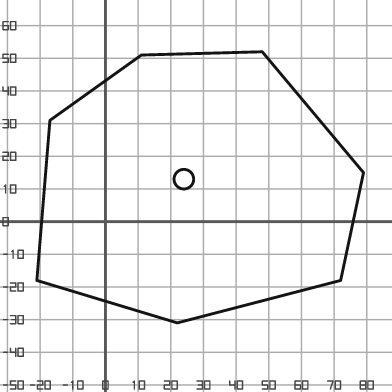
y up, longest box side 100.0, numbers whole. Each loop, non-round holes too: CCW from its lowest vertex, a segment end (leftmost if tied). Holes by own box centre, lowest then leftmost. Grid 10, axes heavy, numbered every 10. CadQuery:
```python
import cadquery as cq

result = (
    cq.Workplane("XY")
    .moveTo(22.0, -31.0)
    .lineTo(72.0, -18.0)
    .lineTo(79.0, 15.0)
    .lineTo(48.0, 52.0)
    .lineTo(11.0, 51.0)
    .lineTo(-17.0, 31.0)
    .lineTo(-21.0, -18.0)
    .close()
    .moveTo(24.0, 13.0)
    .circle(3.0)
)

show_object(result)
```